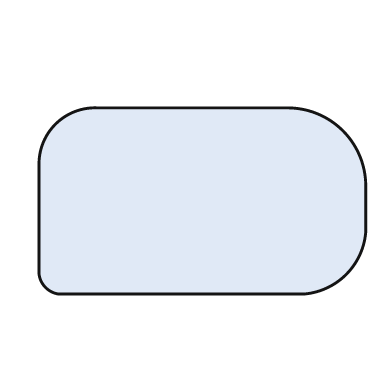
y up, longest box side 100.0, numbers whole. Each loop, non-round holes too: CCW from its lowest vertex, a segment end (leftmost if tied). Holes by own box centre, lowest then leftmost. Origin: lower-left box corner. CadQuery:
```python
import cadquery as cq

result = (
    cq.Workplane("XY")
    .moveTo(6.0, 0.0)
    .lineTo(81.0, 0.0)
    .threePointArc((94.0, 6.0), (100.0, 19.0))
    .lineTo(100.0, 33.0)
    .threePointArc((93.0, 50.0), (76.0, 57.0))
    .lineTo(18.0, 57.0)
    .threePointArc((5.0, 52.0), (0.0, 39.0))
    .lineTo(0.0, 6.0)
    .threePointArc((2.0, 2.0), (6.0, 0.0))
    .close()
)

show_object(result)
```